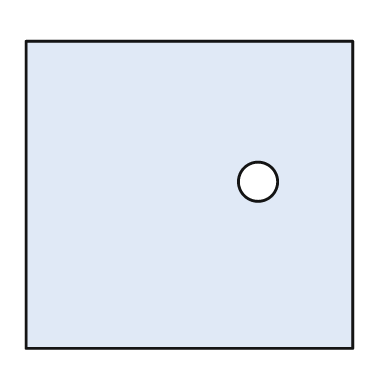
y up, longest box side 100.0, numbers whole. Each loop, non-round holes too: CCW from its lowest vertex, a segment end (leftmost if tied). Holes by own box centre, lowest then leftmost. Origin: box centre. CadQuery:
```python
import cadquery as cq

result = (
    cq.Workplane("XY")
    .moveTo(-50.0, -47.0)
    .lineTo(50.0, -47.0)
    .lineTo(50.0, 47.0)
    .lineTo(-50.0, 47.0)
    .close()
    .moveTo(21.0, 4.0)
    .circle(6.0)
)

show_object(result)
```